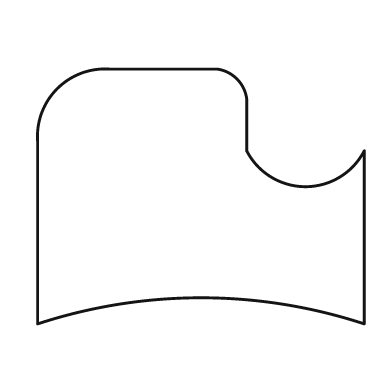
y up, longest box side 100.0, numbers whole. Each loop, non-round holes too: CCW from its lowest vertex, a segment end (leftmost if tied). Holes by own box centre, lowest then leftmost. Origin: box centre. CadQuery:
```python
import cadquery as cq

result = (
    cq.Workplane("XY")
    .moveTo(-50.0, -39.0)
    .threePointArc((0.0, -31.0), (50.0, -39.0))
    .lineTo(50.0, 14.0)
    .threePointArc((32.0, 3.0), (14.0, 14.0))
    .lineTo(14.0, 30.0)
    .threePointArc((11.0, 36.0), (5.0, 39.0))
    .lineTo(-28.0, 39.0)
    .threePointArc((-44.0, 33.0), (-50.0, 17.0))
    .close()
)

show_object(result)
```